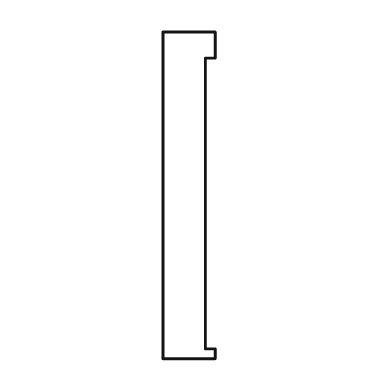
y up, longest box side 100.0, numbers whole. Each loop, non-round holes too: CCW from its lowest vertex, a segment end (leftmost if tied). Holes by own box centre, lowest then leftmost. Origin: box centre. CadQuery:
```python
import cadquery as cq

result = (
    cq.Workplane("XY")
    .moveTo(-8.0, -50.0)
    .lineTo(8.0, -50.0)
    .lineTo(8.0, -47.0)
    .lineTo(5.0, -47.0)
    .lineTo(5.0, 42.0)
    .lineTo(8.0, 42.0)
    .lineTo(8.0, 50.0)
    .lineTo(-8.0, 50.0)
    .close()
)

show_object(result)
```